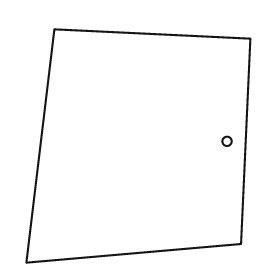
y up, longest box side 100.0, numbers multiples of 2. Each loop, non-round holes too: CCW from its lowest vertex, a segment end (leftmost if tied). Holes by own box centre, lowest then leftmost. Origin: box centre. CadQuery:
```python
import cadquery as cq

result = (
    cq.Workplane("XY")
    .moveTo(-48.0, -50.0)
    .lineTo(44.0, -42.0)
    .lineTo(48.0, 46.0)
    .lineTo(-36.0, 50.0)
    .close()
    .moveTo(38.0, 2.0)
    .circle(2.0)
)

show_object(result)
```